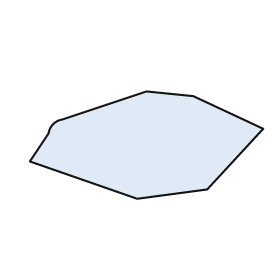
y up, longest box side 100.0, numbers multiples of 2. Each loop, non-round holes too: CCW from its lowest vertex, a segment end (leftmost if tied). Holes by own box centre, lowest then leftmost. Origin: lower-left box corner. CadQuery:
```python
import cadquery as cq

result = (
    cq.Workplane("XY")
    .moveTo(46.0, 0.0)
    .lineTo(76.0, 4.0)
    .lineTo(100.0, 30.0)
    .lineTo(70.0, 44.0)
    .lineTo(50.0, 46.0)
    .lineTo(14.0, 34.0)
    .threePointArc((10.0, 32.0), (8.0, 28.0))
    .lineTo(0.0, 16.0)
    .close()
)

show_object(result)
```